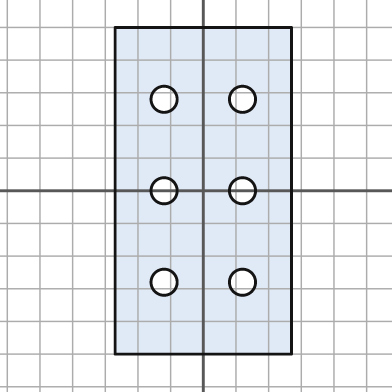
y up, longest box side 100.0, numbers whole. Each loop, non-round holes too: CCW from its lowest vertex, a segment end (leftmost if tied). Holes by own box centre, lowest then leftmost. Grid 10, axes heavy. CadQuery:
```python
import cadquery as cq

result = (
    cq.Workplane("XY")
    .moveTo(-27.0, -50.0)
    .lineTo(27.0, -50.0)
    .lineTo(27.0, 50.0)
    .lineTo(-27.0, 50.0)
    .close()
    .moveTo(-12.0, -28.0)
    .circle(4.0)
    .moveTo(12.0, -28.0)
    .circle(4.0)
    .moveTo(-12.0, 0.0)
    .circle(4.0)
    .moveTo(12.0, 0.0)
    .circle(4.0)
    .moveTo(-12.0, 28.0)
    .circle(4.0)
    .moveTo(12.0, 28.0)
    .circle(4.0)
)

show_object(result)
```